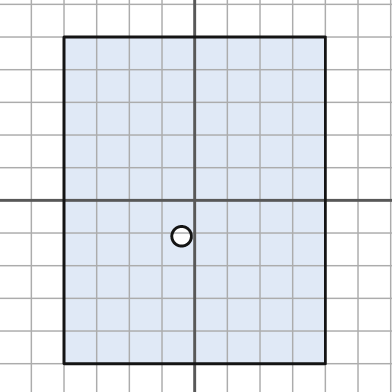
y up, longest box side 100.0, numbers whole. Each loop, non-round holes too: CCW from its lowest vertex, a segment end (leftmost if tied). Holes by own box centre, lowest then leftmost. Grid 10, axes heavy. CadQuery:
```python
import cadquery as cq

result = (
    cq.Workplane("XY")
    .moveTo(-40.0, -50.0)
    .lineTo(40.0, -50.0)
    .lineTo(40.0, 50.0)
    .lineTo(-40.0, 50.0)
    .close()
    .moveTo(-4.0, -11.0)
    .circle(3.0)
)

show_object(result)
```